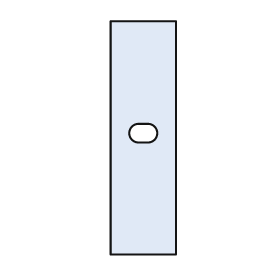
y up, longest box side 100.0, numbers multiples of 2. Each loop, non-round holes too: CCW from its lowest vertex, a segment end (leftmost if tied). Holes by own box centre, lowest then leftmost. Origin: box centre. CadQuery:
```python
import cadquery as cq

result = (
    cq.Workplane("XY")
    .moveTo(-14.0, -50.0)
    .lineTo(14.0, -50.0)
    .lineTo(14.0, 50.0)
    .lineTo(-14.0, 50.0)
    .close()
    .moveTo(-2.0, -2.0)
    .lineTo(2.0, -2.0)
    .threePointArc((6.0, 2.0), (2.0, 6.0))
    .lineTo(-2.0, 6.0)
    .threePointArc((-6.0, 2.0), (-2.0, -2.0))
    .close()
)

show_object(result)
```